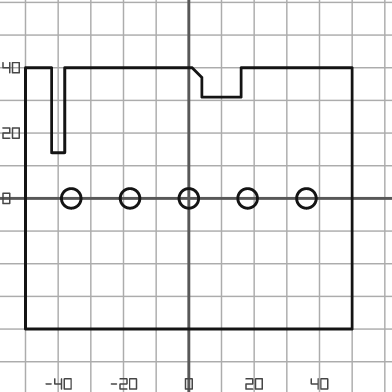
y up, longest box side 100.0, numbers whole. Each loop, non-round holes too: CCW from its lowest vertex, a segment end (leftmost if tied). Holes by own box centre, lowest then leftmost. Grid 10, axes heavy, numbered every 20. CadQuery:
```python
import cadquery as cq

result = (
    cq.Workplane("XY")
    .moveTo(-50.0, -40.0)
    .lineTo(50.0, -40.0)
    .lineTo(50.0, 40.0)
    .lineTo(16.0, 40.0)
    .lineTo(16.0, 31.0)
    .lineTo(4.0, 31.0)
    .lineTo(4.0, 37.0)
    .lineTo(1.0, 40.0)
    .lineTo(-38.0, 40.0)
    .lineTo(-38.0, 14.0)
    .lineTo(-42.0, 14.0)
    .lineTo(-42.0, 40.0)
    .lineTo(-50.0, 40.0)
    .close()
    .moveTo(-36.0, 0.0)
    .circle(3.0)
    .moveTo(-18.0, 0.0)
    .circle(3.0)
    .moveTo(0.0, 0.0)
    .circle(3.0)
    .moveTo(18.0, 0.0)
    .circle(3.0)
    .moveTo(36.0, 0.0)
    .circle(3.0)
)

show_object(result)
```